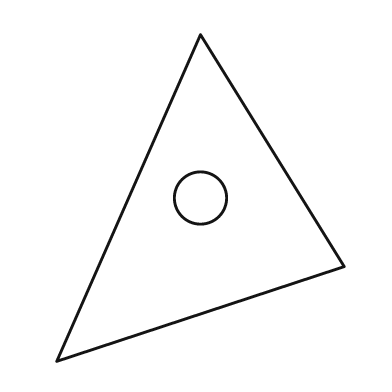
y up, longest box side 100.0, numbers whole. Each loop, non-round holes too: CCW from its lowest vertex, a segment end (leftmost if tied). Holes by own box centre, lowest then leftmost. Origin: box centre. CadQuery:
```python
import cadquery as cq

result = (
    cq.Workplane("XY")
    .moveTo(-44.0, -50.0)
    .lineTo(44.0, -21.0)
    .lineTo(0.0, 50.0)
    .close()
    .moveTo(0.0, 0.0)
    .circle(8.0)
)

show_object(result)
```